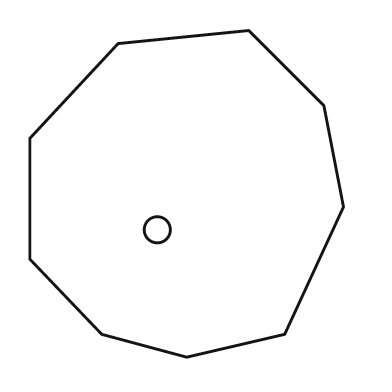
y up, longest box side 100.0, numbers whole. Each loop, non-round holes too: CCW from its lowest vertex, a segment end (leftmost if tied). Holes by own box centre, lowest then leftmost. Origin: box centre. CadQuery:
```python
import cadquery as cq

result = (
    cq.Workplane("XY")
    .moveTo(0.0, -50.0)
    .lineTo(30.0, -43.0)
    .lineTo(48.0, -4.0)
    .lineTo(42.0, 27.0)
    .lineTo(19.0, 50.0)
    .lineTo(-21.0, 46.0)
    .lineTo(-48.0, 17.0)
    .lineTo(-48.0, -20.0)
    .lineTo(-26.0, -43.0)
    .close()
    .moveTo(-9.0, -11.0)
    .circle(4.0)
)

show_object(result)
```